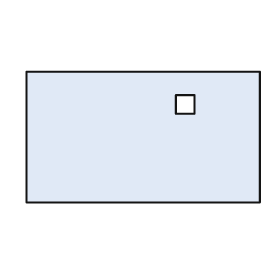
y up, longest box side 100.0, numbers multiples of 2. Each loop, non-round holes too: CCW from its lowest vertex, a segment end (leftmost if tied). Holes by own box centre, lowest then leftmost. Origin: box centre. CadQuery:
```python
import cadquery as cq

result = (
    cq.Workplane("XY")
    .moveTo(-50.0, -28.0)
    .lineTo(50.0, -28.0)
    .lineTo(50.0, 28.0)
    .lineTo(-50.0, 28.0)
    .close()
    .moveTo(14.0, 10.0)
    .lineTo(22.0, 10.0)
    .lineTo(22.0, 18.0)
    .lineTo(14.0, 18.0)
    .close()
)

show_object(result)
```